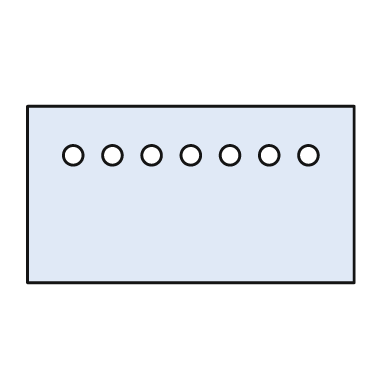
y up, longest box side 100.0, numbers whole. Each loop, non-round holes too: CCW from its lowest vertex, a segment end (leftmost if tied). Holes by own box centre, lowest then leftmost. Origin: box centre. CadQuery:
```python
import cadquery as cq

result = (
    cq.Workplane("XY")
    .moveTo(-50.0, -27.0)
    .lineTo(50.0, -27.0)
    .lineTo(50.0, 27.0)
    .lineTo(-50.0, 27.0)
    .close()
    .moveTo(-36.0, 12.0)
    .circle(3.0)
    .moveTo(-24.0, 12.0)
    .circle(3.0)
    .moveTo(-12.0, 12.0)
    .circle(3.0)
    .moveTo(0.0, 12.0)
    .circle(3.0)
    .moveTo(12.0, 12.0)
    .circle(3.0)
    .moveTo(24.0, 12.0)
    .circle(3.0)
    .moveTo(36.0, 12.0)
    .circle(3.0)
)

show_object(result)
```